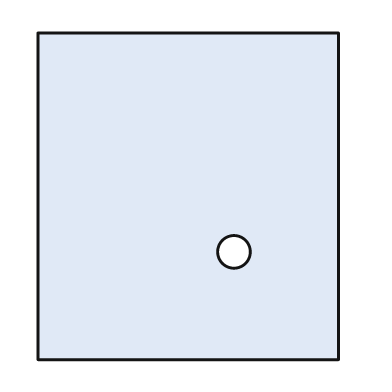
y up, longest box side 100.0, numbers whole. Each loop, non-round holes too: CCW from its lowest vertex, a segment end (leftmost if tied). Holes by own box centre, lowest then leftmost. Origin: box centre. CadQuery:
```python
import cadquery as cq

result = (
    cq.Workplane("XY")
    .moveTo(-46.0, -50.0)
    .lineTo(46.0, -50.0)
    .lineTo(46.0, 50.0)
    .lineTo(-46.0, 50.0)
    .close()
    .moveTo(14.0, -17.0)
    .circle(5.0)
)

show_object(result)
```